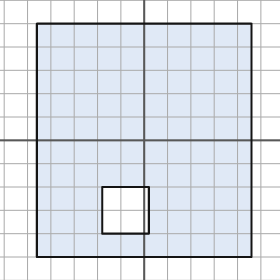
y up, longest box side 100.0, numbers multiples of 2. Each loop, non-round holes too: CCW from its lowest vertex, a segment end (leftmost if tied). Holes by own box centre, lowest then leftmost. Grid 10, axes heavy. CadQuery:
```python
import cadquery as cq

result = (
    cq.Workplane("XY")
    .moveTo(-46.0, -50.0)
    .lineTo(46.0, -50.0)
    .lineTo(46.0, 50.0)
    .lineTo(-46.0, 50.0)
    .close()
    .moveTo(-18.0, -40.0)
    .lineTo(2.0, -40.0)
    .lineTo(2.0, -20.0)
    .lineTo(-18.0, -20.0)
    .close()
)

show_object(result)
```